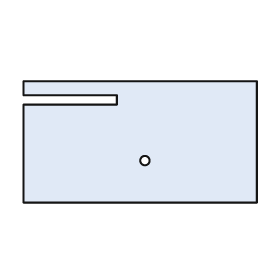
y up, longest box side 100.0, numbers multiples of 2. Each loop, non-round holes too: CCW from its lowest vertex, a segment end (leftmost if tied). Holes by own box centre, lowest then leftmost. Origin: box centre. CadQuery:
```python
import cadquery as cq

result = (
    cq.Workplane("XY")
    .moveTo(-50.0, -26.0)
    .lineTo(50.0, -26.0)
    .lineTo(50.0, 26.0)
    .lineTo(-50.0, 26.0)
    .lineTo(-50.0, 20.0)
    .lineTo(-10.0, 20.0)
    .lineTo(-10.0, 16.0)
    .lineTo(-50.0, 16.0)
    .close()
    .moveTo(2.0, -8.0)
    .circle(2.0)
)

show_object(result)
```